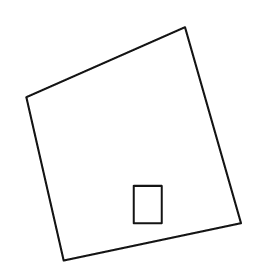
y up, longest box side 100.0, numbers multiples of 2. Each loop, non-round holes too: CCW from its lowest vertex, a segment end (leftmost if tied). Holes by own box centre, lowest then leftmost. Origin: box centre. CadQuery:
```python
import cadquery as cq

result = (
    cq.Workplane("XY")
    .moveTo(-30.0, -50.0)
    .lineTo(46.0, -34.0)
    .lineTo(22.0, 50.0)
    .lineTo(-46.0, 20.0)
    .close()
    .moveTo(0.0, -34.0)
    .lineTo(12.0, -34.0)
    .lineTo(12.0, -18.0)
    .lineTo(0.0, -18.0)
    .close()
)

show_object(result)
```